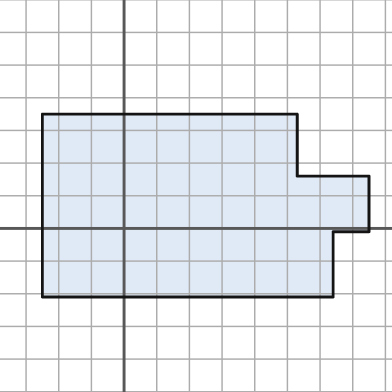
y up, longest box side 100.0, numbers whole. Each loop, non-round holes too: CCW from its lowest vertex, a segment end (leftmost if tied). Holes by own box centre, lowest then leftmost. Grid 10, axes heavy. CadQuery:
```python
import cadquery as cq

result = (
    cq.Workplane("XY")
    .moveTo(-25.0, -21.0)
    .lineTo(64.0, -21.0)
    .lineTo(64.0, -1.0)
    .lineTo(75.0, -1.0)
    .lineTo(75.0, 16.0)
    .lineTo(53.0, 16.0)
    .lineTo(53.0, 35.0)
    .lineTo(-25.0, 35.0)
    .close()
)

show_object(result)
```